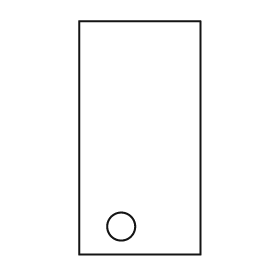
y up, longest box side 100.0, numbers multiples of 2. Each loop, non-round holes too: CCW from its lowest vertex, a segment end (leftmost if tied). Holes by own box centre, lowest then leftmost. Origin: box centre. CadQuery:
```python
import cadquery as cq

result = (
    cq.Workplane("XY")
    .moveTo(-26.0, -50.0)
    .lineTo(26.0, -50.0)
    .lineTo(26.0, 50.0)
    .lineTo(-26.0, 50.0)
    .close()
    .moveTo(-8.0, -38.0)
    .circle(6.0)
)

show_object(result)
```